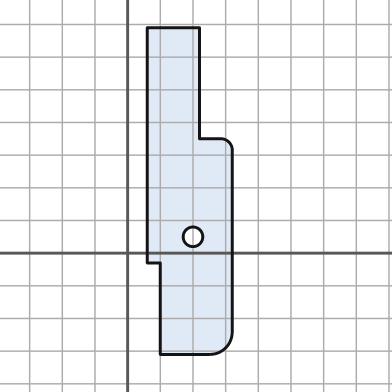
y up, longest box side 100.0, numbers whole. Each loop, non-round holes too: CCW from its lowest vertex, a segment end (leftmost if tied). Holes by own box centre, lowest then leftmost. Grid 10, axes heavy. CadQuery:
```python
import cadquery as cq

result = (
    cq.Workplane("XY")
    .moveTo(10.0, -31.0)
    .lineTo(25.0, -31.0)
    .threePointArc((30.0, -29.0), (32.0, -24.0))
    .lineTo(32.0, 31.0)
    .threePointArc((31.0, 34.0), (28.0, 35.0))
    .lineTo(22.0, 35.0)
    .lineTo(22.0, 69.0)
    .lineTo(6.0, 69.0)
    .lineTo(6.0, -3.0)
    .lineTo(10.0, -3.0)
    .close()
    .moveTo(20.0, 5.0)
    .circle(3.0)
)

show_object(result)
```